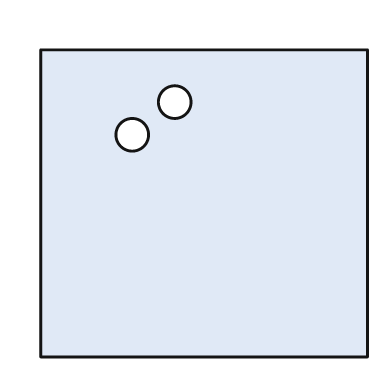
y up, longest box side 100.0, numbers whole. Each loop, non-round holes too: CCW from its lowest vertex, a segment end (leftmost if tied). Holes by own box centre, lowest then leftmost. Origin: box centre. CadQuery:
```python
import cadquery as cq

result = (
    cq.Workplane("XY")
    .moveTo(-50.0, -47.0)
    .lineTo(50.0, -47.0)
    .lineTo(50.0, 47.0)
    .lineTo(-50.0, 47.0)
    .close()
    .moveTo(-22.0, 21.0)
    .circle(5.0)
    .moveTo(-9.0, 31.0)
    .circle(5.0)
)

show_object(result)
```